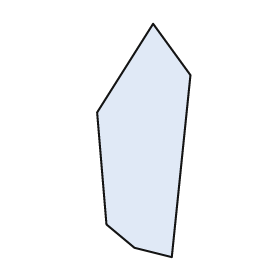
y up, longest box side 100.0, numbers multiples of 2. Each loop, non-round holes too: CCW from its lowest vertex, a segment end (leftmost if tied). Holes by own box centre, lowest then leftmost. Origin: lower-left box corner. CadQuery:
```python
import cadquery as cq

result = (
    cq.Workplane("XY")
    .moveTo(32.0, 0.0)
    .lineTo(40.0, 78.0)
    .lineTo(24.0, 100.0)
    .lineTo(0.0, 62.0)
    .lineTo(4.0, 14.0)
    .lineTo(16.0, 4.0)
    .close()
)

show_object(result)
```